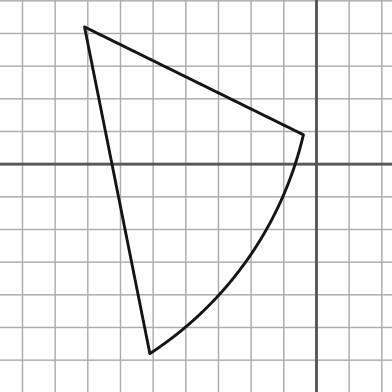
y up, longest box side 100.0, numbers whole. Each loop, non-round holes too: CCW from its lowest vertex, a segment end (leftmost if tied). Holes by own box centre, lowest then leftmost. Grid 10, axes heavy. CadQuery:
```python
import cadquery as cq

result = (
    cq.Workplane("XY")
    .moveTo(-51.0, -58.0)
    .threePointArc((-21.0, -29.0), (-4.0, 9.0))
    .lineTo(-71.0, 42.0)
    .close()
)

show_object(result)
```